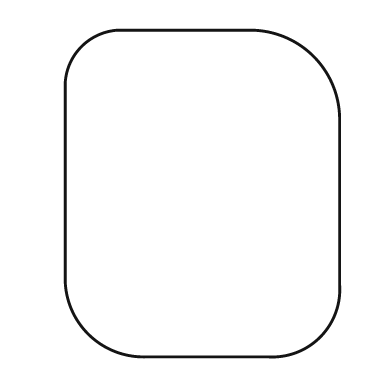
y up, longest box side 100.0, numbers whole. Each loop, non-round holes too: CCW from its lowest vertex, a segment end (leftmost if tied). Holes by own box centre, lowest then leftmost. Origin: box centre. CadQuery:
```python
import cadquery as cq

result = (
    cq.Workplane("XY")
    .moveTo(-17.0, -50.0)
    .lineTo(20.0, -50.0)
    .threePointArc((36.0, -44.0), (42.0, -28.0))
    .lineTo(42.0, 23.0)
    .threePointArc((34.0, 42.0), (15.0, 50.0))
    .lineTo(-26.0, 50.0)
    .threePointArc((-37.0, 45.0), (-42.0, 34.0))
    .lineTo(-42.0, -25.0)
    .threePointArc((-35.0, -43.0), (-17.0, -50.0))
    .close()
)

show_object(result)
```